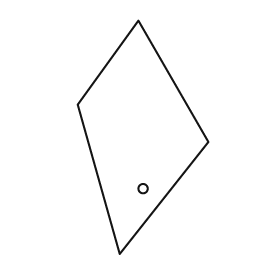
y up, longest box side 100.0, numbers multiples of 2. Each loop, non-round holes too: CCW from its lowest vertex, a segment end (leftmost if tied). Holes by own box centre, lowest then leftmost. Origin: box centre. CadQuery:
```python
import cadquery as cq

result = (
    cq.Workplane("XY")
    .moveTo(-10.0, -50.0)
    .lineTo(28.0, -2.0)
    .lineTo(-2.0, 50.0)
    .lineTo(-28.0, 14.0)
    .close()
    .moveTo(0.0, -22.0)
    .circle(2.0)
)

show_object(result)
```